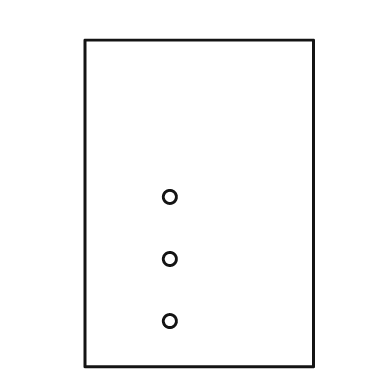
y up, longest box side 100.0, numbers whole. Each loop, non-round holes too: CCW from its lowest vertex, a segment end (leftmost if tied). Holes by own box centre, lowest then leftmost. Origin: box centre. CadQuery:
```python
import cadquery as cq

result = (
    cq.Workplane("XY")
    .moveTo(-35.0, -50.0)
    .lineTo(35.0, -50.0)
    .lineTo(35.0, 50.0)
    .lineTo(-35.0, 50.0)
    .close()
    .moveTo(-9.0, -36.0)
    .circle(2.0)
    .moveTo(-9.0, -17.0)
    .circle(2.0)
    .moveTo(-9.0, 2.0)
    .circle(2.0)
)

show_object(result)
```